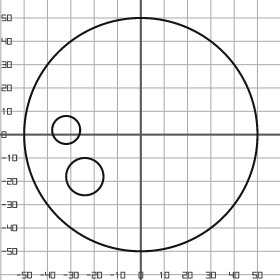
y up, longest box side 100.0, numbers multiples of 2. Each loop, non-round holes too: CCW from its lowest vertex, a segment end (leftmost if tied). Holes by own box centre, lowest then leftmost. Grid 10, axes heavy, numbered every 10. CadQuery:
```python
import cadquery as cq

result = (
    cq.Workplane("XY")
    .moveTo(0.0, 0.0)
    .circle(50.0)
    .moveTo(-24.0, -18.0)
    .circle(8.0)
    .moveTo(-32.0, 2.0)
    .circle(6.0)
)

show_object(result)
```